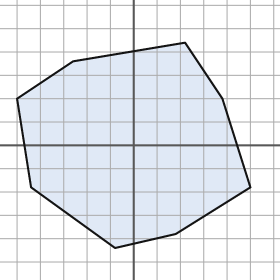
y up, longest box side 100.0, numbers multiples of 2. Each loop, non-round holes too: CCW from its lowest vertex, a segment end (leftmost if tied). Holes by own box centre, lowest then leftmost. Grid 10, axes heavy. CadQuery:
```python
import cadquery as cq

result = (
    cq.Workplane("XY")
    .moveTo(-8.0, -44.0)
    .lineTo(18.0, -38.0)
    .lineTo(50.0, -18.0)
    .lineTo(38.0, 20.0)
    .lineTo(22.0, 44.0)
    .lineTo(-26.0, 36.0)
    .lineTo(-50.0, 20.0)
    .lineTo(-44.0, -18.0)
    .close()
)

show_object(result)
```